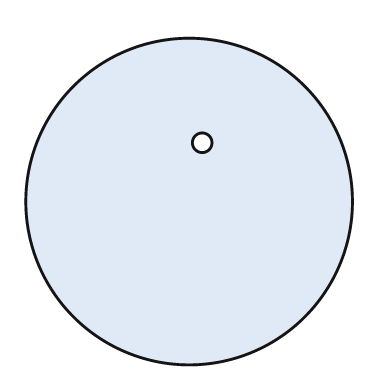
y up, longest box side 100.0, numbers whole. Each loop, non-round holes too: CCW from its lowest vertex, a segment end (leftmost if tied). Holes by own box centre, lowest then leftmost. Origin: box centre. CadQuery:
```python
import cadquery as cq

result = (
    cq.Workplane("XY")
    .moveTo(0.0, 0.0)
    .circle(50.0)
    .moveTo(4.0, 18.0)
    .circle(3.0)
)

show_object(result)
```